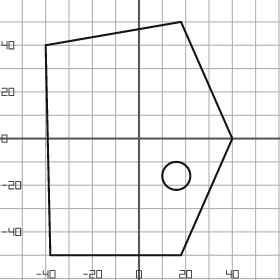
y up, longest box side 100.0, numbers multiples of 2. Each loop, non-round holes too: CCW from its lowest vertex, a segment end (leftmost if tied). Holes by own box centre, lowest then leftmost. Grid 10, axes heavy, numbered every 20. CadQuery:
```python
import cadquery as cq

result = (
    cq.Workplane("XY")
    .moveTo(-38.0, -50.0)
    .lineTo(18.0, -50.0)
    .lineTo(40.0, 0.0)
    .lineTo(18.0, 50.0)
    .lineTo(-40.0, 40.0)
    .close()
    .moveTo(16.0, -16.0)
    .circle(6.0)
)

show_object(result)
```